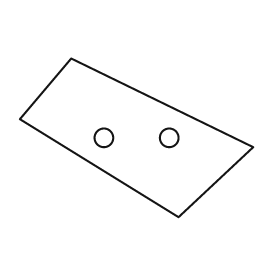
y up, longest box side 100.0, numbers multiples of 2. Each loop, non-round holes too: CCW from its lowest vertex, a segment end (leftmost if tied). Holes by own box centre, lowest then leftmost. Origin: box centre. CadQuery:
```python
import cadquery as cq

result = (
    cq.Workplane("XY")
    .moveTo(18.0, -34.0)
    .lineTo(50.0, -4.0)
    .lineTo(-28.0, 34.0)
    .lineTo(-50.0, 8.0)
    .close()
    .moveTo(-14.0, 0.0)
    .circle(4.0)
    .moveTo(14.0, 0.0)
    .circle(4.0)
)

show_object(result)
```